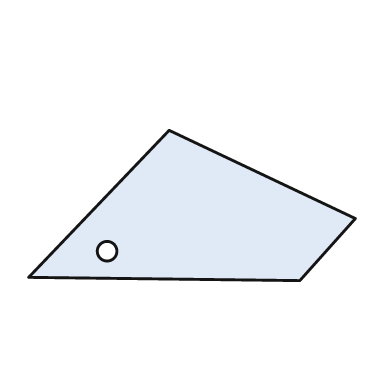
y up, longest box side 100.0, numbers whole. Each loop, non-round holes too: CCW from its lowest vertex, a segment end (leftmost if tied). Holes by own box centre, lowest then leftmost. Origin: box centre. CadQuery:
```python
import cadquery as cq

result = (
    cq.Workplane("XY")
    .moveTo(33.0, -23.0)
    .lineTo(50.0, -4.0)
    .lineTo(-7.0, 23.0)
    .lineTo(-50.0, -22.0)
    .close()
    .moveTo(-26.0, -14.0)
    .circle(3.0)
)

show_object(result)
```